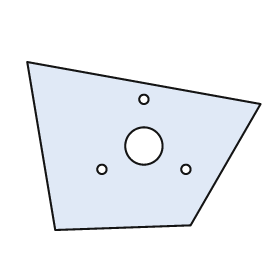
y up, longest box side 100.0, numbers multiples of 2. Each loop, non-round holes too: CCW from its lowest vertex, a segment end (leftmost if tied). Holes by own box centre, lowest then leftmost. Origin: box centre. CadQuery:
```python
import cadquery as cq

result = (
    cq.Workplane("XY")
    .moveTo(-38.0, -36.0)
    .lineTo(20.0, -34.0)
    .lineTo(50.0, 18.0)
    .lineTo(-50.0, 36.0)
    .close()
    .moveTo(-18.0, -10.0)
    .circle(2.0)
    .moveTo(18.0, -10.0)
    .circle(2.0)
    .moveTo(0.0, 0.0)
    .circle(8.0)
    .moveTo(0.0, 20.0)
    .circle(2.0)
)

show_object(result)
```